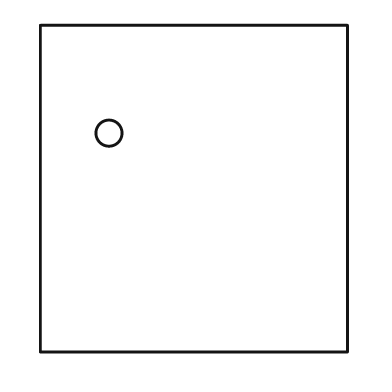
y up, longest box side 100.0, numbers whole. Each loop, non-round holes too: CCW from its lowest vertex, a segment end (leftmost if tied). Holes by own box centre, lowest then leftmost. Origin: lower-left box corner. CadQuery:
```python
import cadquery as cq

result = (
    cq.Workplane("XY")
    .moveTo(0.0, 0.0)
    .lineTo(94.0, 0.0)
    .lineTo(94.0, 100.0)
    .lineTo(0.0, 100.0)
    .close()
    .moveTo(21.0, 67.0)
    .circle(4.0)
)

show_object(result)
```